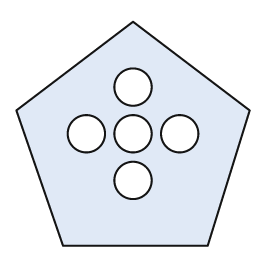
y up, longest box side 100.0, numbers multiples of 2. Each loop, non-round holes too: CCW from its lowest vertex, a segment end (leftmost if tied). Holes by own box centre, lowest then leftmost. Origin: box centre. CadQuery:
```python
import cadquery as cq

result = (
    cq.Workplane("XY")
    .moveTo(-30.0, -48.0)
    .lineTo(32.0, -48.0)
    .lineTo(50.0, 10.0)
    .lineTo(0.0, 48.0)
    .lineTo(-50.0, 10.0)
    .close()
    .moveTo(0.0, -20.0)
    .circle(8.0)
    .moveTo(-20.0, 0.0)
    .circle(8.0)
    .moveTo(0.0, 0.0)
    .circle(8.0)
    .moveTo(20.0, 0.0)
    .circle(8.0)
    .moveTo(0.0, 20.0)
    .circle(8.0)
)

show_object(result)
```